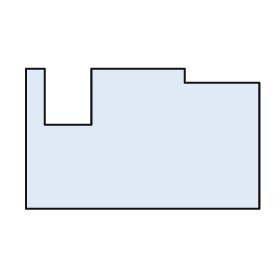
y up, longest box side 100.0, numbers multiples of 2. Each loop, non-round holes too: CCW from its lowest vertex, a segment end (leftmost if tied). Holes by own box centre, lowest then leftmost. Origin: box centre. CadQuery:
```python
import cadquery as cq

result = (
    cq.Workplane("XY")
    .moveTo(-50.0, -30.0)
    .lineTo(50.0, -30.0)
    .lineTo(50.0, 24.0)
    .lineTo(18.0, 24.0)
    .lineTo(18.0, 30.0)
    .lineTo(-22.0, 30.0)
    .lineTo(-22.0, 6.0)
    .lineTo(-42.0, 6.0)
    .lineTo(-42.0, 30.0)
    .lineTo(-50.0, 30.0)
    .close()
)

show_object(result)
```